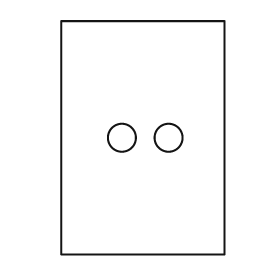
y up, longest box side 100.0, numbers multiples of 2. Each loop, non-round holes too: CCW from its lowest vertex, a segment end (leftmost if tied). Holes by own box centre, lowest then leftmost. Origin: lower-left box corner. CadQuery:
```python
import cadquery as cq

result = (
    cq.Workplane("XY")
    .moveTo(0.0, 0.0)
    .lineTo(70.0, 0.0)
    .lineTo(70.0, 100.0)
    .lineTo(0.0, 100.0)
    .close()
    .moveTo(26.0, 50.0)
    .circle(6.0)
    .moveTo(46.0, 50.0)
    .circle(6.0)
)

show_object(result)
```